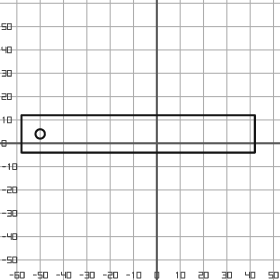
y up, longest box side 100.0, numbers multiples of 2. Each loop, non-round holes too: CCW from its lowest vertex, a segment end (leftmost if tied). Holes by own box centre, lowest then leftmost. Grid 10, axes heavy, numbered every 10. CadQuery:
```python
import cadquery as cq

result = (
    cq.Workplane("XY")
    .moveTo(-58.0, -4.0)
    .lineTo(42.0, -4.0)
    .lineTo(42.0, 12.0)
    .lineTo(-58.0, 12.0)
    .close()
    .moveTo(-50.0, 4.0)
    .circle(2.0)
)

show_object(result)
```